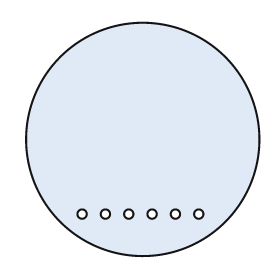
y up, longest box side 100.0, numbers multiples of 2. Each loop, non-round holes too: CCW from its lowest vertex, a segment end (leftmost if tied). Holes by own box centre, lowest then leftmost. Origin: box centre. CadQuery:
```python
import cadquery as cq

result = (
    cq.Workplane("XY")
    .moveTo(0.0, 0.0)
    .circle(50.0)
    .moveTo(-26.0, -32.0)
    .circle(2.0)
    .moveTo(-16.0, -32.0)
    .circle(2.0)
    .moveTo(-6.0, -32.0)
    .circle(2.0)
    .moveTo(4.0, -32.0)
    .circle(2.0)
    .moveTo(14.0, -32.0)
    .circle(2.0)
    .moveTo(24.0, -32.0)
    .circle(2.0)
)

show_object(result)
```